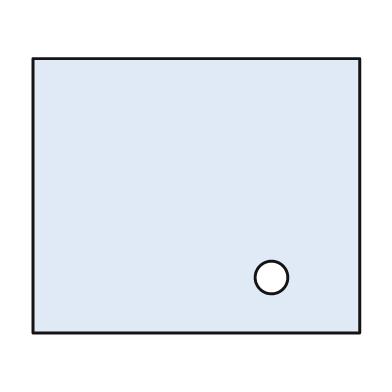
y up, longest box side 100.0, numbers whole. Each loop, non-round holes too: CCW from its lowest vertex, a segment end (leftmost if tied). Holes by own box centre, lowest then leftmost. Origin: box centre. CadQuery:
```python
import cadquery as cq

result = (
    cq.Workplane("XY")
    .moveTo(-50.0, -42.0)
    .lineTo(50.0, -42.0)
    .lineTo(50.0, 42.0)
    .lineTo(-50.0, 42.0)
    .close()
    .moveTo(23.0, -25.0)
    .circle(5.0)
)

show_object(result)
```